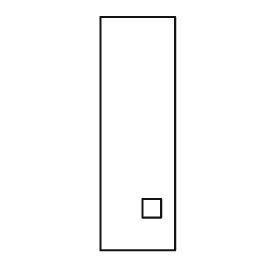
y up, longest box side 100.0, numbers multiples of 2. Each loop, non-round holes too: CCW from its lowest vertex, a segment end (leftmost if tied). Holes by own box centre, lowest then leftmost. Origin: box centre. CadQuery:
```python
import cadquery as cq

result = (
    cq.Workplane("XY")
    .moveTo(-16.0, -50.0)
    .lineTo(16.0, -50.0)
    .lineTo(16.0, 50.0)
    .lineTo(-16.0, 50.0)
    .close()
    .moveTo(2.0, -36.0)
    .lineTo(10.0, -36.0)
    .lineTo(10.0, -28.0)
    .lineTo(2.0, -28.0)
    .close()
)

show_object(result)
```